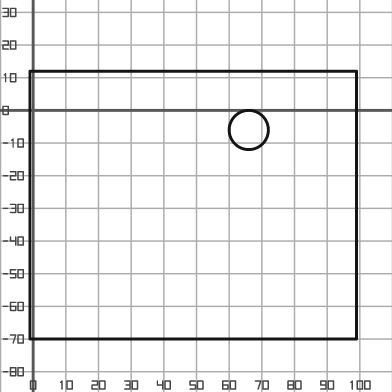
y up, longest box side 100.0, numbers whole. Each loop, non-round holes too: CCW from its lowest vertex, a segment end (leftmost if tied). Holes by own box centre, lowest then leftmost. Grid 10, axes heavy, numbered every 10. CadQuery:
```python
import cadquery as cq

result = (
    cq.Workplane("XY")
    .moveTo(-1.0, -70.0)
    .lineTo(99.0, -70.0)
    .lineTo(99.0, 12.0)
    .lineTo(-1.0, 12.0)
    .close()
    .moveTo(66.0, -6.0)
    .circle(6.0)
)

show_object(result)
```